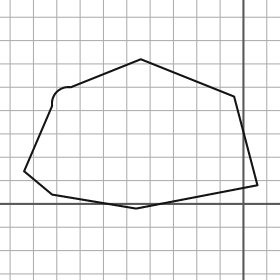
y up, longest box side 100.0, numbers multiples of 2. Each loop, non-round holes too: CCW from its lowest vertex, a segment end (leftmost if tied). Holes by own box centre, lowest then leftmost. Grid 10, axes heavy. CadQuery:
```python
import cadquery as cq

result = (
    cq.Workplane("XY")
    .moveTo(-46.0, -2.0)
    .lineTo(6.0, 8.0)
    .lineTo(-4.0, 46.0)
    .lineTo(-44.0, 62.0)
    .lineTo(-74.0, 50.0)
    .threePointArc((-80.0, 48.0), (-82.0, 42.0))
    .lineTo(-94.0, 14.0)
    .lineTo(-82.0, 4.0)
    .close()
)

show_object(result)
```